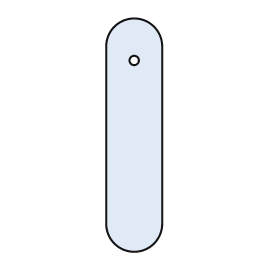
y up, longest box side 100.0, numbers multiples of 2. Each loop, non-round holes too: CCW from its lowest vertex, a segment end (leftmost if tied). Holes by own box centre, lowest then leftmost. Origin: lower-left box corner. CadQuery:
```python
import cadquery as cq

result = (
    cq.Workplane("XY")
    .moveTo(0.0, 12.0)
    .threePointArc((12.0, 0.0), (24.0, 12.0))
    .lineTo(24.0, 88.0)
    .threePointArc((12.0, 100.0), (0.0, 88.0))
    .close()
    .moveTo(12.0, 82.0)
    .circle(2.0)
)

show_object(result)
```